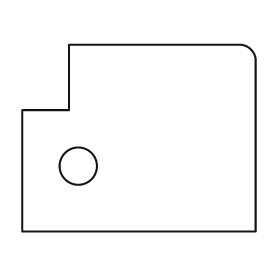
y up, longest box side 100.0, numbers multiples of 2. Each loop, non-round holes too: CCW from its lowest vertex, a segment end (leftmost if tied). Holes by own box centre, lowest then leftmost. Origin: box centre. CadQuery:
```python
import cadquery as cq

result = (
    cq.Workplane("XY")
    .moveTo(-50.0, -40.0)
    .lineTo(50.0, -40.0)
    .lineTo(50.0, 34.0)
    .threePointArc((48.0, 38.0), (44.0, 40.0))
    .lineTo(-30.0, 40.0)
    .lineTo(-30.0, 12.0)
    .lineTo(-50.0, 12.0)
    .close()
    .moveTo(-26.0, -12.0)
    .circle(8.0)
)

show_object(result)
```